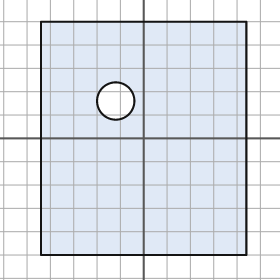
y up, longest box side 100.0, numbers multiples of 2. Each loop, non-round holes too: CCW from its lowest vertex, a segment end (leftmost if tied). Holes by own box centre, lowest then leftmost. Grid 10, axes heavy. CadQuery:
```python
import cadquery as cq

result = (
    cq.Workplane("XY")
    .moveTo(-44.0, -50.0)
    .lineTo(44.0, -50.0)
    .lineTo(44.0, 50.0)
    .lineTo(-44.0, 50.0)
    .close()
    .moveTo(-12.0, 16.0)
    .circle(8.0)
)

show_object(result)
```